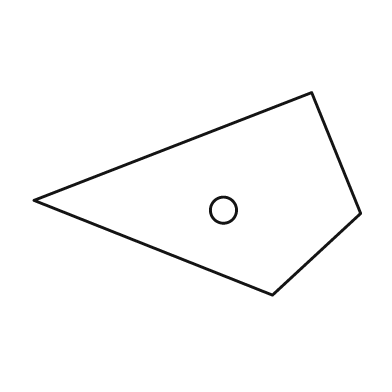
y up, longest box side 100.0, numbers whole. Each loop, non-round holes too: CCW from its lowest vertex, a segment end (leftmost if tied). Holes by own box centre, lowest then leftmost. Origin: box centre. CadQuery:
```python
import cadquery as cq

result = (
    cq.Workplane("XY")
    .moveTo(23.0, -31.0)
    .lineTo(50.0, -6.0)
    .lineTo(35.0, 31.0)
    .lineTo(-50.0, -2.0)
    .close()
    .moveTo(8.0, -5.0)
    .circle(4.0)
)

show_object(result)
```